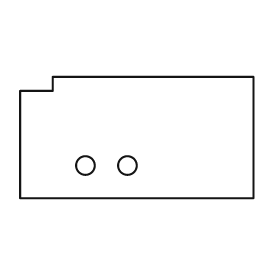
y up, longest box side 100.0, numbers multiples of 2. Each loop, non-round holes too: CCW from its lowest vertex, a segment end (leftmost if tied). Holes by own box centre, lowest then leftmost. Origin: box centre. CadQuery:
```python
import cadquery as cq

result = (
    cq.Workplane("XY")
    .moveTo(-50.0, -26.0)
    .lineTo(50.0, -26.0)
    .lineTo(50.0, 26.0)
    .lineTo(-36.0, 26.0)
    .lineTo(-36.0, 20.0)
    .lineTo(-50.0, 20.0)
    .close()
    .moveTo(-22.0, -12.0)
    .circle(4.0)
    .moveTo(-4.0, -12.0)
    .circle(4.0)
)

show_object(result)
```